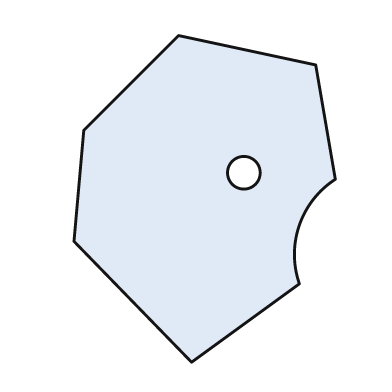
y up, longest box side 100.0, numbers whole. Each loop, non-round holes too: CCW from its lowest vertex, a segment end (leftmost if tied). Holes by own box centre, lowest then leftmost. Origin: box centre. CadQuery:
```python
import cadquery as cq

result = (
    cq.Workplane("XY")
    .moveTo(-4.0, -50.0)
    .lineTo(29.0, -26.0)
    .threePointArc((29.0, -8.0), (40.0, 6.0))
    .lineTo(34.0, 41.0)
    .lineTo(-8.0, 50.0)
    .lineTo(-37.0, 21.0)
    .lineTo(-40.0, -13.0)
    .close()
    .moveTo(12.0, 8.0)
    .circle(5.0)
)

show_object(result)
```